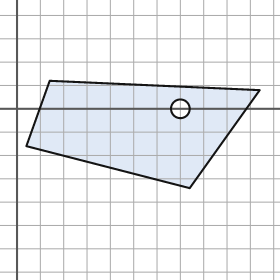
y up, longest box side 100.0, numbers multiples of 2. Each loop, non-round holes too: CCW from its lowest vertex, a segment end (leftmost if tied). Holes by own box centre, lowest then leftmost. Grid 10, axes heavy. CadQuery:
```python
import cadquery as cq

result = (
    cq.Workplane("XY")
    .moveTo(74.0, -34.0)
    .lineTo(104.0, 8.0)
    .lineTo(14.0, 12.0)
    .lineTo(4.0, -16.0)
    .close()
    .moveTo(70.0, 0.0)
    .circle(4.0)
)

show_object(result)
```